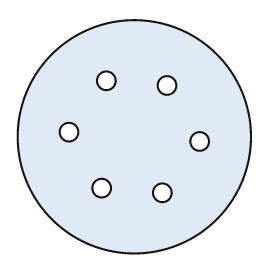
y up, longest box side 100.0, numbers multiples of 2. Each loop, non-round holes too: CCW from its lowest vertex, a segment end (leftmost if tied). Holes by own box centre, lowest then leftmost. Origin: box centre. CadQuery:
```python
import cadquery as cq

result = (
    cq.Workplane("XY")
    .moveTo(0.0, 0.0)
    .circle(50.0)
    .moveTo(12.0, -24.0)
    .circle(4.0)
    .moveTo(-14.0, -22.0)
    .circle(4.0)
    .moveTo(28.0, -2.0)
    .circle(4.0)
    .moveTo(-28.0, 2.0)
    .circle(4.0)
    .moveTo(14.0, 22.0)
    .circle(4.0)
    .moveTo(-12.0, 24.0)
    .circle(4.0)
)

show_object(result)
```